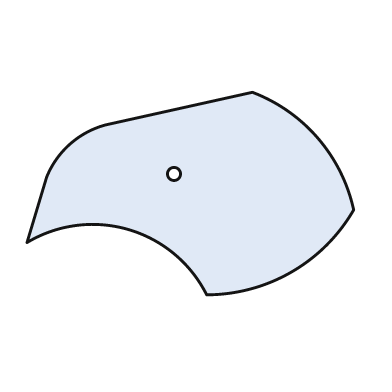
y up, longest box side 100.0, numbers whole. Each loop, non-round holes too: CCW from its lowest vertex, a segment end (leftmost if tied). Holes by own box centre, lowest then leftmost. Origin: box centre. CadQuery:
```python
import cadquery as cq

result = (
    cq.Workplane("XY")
    .moveTo(5.0, -31.0)
    .threePointArc((31.0, -24.0), (50.0, -5.0))
    .threePointArc((39.0, 17.0), (19.0, 31.0))
    .lineTo(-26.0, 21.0)
    .threePointArc((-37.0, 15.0), (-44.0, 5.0))
    .lineTo(-50.0, -15.0)
    .threePointArc((-19.0, -11.0), (5.0, -31.0))
    .close()
    .moveTo(-5.0, 6.0)
    .circle(2.0)
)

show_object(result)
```